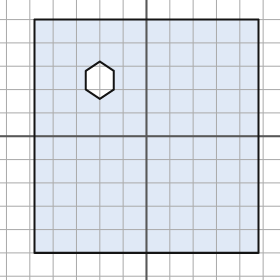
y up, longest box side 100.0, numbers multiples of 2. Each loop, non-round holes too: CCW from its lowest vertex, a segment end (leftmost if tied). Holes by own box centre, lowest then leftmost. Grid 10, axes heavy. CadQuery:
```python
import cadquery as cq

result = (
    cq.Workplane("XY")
    .moveTo(-48.0, -50.0)
    .lineTo(48.0, -50.0)
    .lineTo(48.0, 50.0)
    .lineTo(-48.0, 50.0)
    .close()
    .moveTo(-20.0, 16.0)
    .lineTo(-14.0, 20.0)
    .lineTo(-14.0, 28.0)
    .lineTo(-20.0, 32.0)
    .lineTo(-26.0, 28.0)
    .lineTo(-26.0, 20.0)
    .close()
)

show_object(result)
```